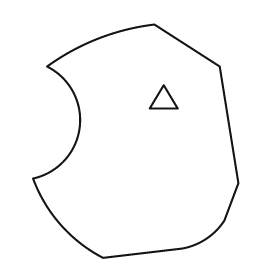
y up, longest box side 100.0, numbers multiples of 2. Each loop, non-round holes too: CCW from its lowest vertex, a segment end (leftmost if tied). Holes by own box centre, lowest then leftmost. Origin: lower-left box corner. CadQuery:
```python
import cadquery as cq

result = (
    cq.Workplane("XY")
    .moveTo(30.0, 0.0)
    .lineTo(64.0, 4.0)
    .threePointArc((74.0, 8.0), (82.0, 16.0))
    .lineTo(88.0, 32.0)
    .lineTo(80.0, 82.0)
    .lineTo(52.0, 100.0)
    .threePointArc((28.0, 94.0), (6.0, 82.0))
    .threePointArc((20.0, 56.0), (0.0, 34.0))
    .threePointArc((12.0, 14.0), (30.0, 0.0))
    .close()
    .moveTo(50.0, 64.0)
    .lineTo(62.0, 64.0)
    .lineTo(56.0, 74.0)
    .close()
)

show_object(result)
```